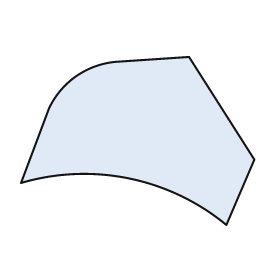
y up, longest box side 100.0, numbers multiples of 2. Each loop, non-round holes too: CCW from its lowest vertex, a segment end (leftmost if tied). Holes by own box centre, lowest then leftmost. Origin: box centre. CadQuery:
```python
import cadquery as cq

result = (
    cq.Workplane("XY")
    .moveTo(38.0, -36.0)
    .lineTo(50.0, -8.0)
    .lineTo(22.0, 36.0)
    .lineTo(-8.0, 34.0)
    .threePointArc((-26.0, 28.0), (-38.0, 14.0))
    .lineTo(-50.0, -18.0)
    .threePointArc((-4.0, -16.0), (38.0, -36.0))
    .close()
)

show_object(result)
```